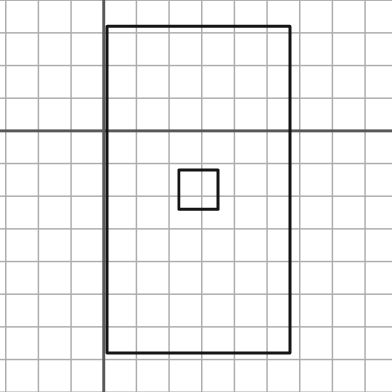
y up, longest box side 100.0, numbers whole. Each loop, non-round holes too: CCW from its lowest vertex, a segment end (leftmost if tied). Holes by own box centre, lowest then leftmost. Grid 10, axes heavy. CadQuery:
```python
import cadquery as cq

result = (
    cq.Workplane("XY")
    .moveTo(1.0, -68.0)
    .lineTo(57.0, -68.0)
    .lineTo(57.0, 32.0)
    .lineTo(1.0, 32.0)
    .close()
    .moveTo(23.0, -24.0)
    .lineTo(35.0, -24.0)
    .lineTo(35.0, -12.0)
    .lineTo(23.0, -12.0)
    .close()
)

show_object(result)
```